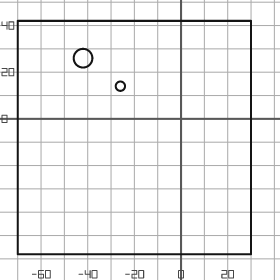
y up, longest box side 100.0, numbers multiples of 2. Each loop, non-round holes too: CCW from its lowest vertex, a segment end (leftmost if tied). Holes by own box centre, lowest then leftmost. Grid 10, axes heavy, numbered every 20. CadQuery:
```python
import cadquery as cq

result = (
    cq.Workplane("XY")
    .moveTo(-70.0, -58.0)
    .lineTo(30.0, -58.0)
    .lineTo(30.0, 42.0)
    .lineTo(-70.0, 42.0)
    .close()
    .moveTo(-26.0, 14.0)
    .circle(2.0)
    .moveTo(-42.0, 26.0)
    .circle(4.0)
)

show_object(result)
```